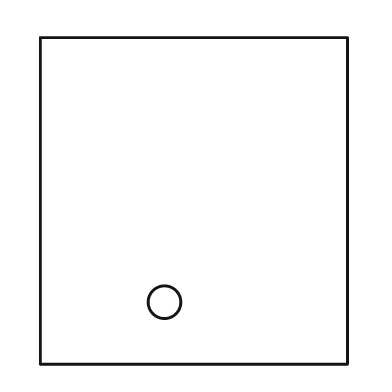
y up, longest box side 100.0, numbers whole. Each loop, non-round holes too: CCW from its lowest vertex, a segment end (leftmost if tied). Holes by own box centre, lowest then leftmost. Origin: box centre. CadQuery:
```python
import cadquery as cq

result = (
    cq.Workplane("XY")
    .moveTo(-47.0, -50.0)
    .lineTo(47.0, -50.0)
    .lineTo(47.0, 50.0)
    .lineTo(-47.0, 50.0)
    .close()
    .moveTo(-9.0, -31.0)
    .circle(5.0)
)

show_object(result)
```